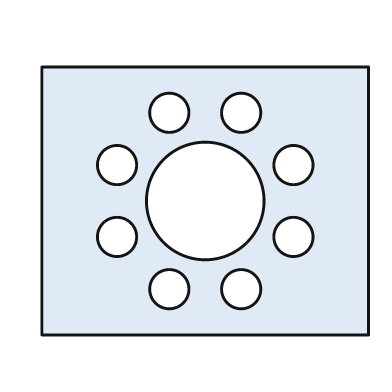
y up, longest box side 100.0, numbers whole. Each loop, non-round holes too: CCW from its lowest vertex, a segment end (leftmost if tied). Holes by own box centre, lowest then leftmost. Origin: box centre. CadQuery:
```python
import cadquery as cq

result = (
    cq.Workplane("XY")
    .moveTo(-50.0, -41.0)
    .lineTo(50.0, -41.0)
    .lineTo(50.0, 41.0)
    .lineTo(-50.0, 41.0)
    .close()
    .moveTo(-11.0, -27.0)
    .circle(6.0)
    .moveTo(11.0, -27.0)
    .circle(6.0)
    .moveTo(-27.0, -11.0)
    .circle(6.0)
    .moveTo(27.0, -11.0)
    .circle(6.0)
    .moveTo(0.0, 0.0)
    .circle(18.0)
    .moveTo(-27.0, 11.0)
    .circle(6.0)
    .moveTo(27.0, 11.0)
    .circle(6.0)
    .moveTo(-11.0, 27.0)
    .circle(6.0)
    .moveTo(11.0, 27.0)
    .circle(6.0)
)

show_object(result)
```